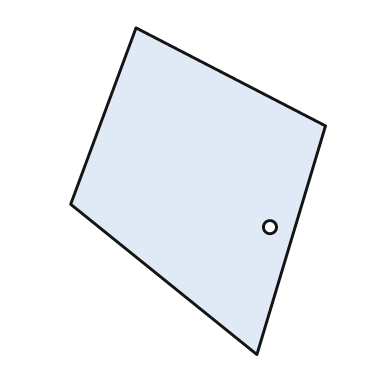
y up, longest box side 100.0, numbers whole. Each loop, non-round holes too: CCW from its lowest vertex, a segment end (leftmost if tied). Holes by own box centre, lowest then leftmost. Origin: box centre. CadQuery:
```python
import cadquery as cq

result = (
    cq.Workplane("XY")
    .moveTo(18.0, -50.0)
    .lineTo(39.0, 20.0)
    .lineTo(-19.0, 50.0)
    .lineTo(-39.0, -4.0)
    .close()
    .moveTo(22.0, -11.0)
    .circle(2.0)
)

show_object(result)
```